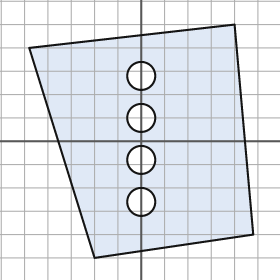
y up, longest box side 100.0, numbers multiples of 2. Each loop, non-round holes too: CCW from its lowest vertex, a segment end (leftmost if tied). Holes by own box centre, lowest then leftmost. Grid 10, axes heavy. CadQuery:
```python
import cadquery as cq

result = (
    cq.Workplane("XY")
    .moveTo(-20.0, -50.0)
    .lineTo(48.0, -40.0)
    .lineTo(40.0, 50.0)
    .lineTo(-48.0, 40.0)
    .close()
    .moveTo(0.0, -26.0)
    .circle(6.0)
    .moveTo(0.0, -8.0)
    .circle(6.0)
    .moveTo(0.0, 10.0)
    .circle(6.0)
    .moveTo(0.0, 28.0)
    .circle(6.0)
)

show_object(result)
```